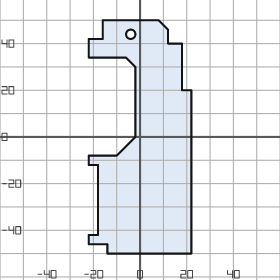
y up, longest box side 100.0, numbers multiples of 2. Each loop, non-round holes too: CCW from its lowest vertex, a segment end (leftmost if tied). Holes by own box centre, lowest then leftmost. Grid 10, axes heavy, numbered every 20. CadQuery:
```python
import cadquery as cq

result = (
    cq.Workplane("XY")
    .moveTo(-14.0, -50.0)
    .lineTo(22.0, -50.0)
    .lineTo(22.0, 20.0)
    .lineTo(18.0, 20.0)
    .lineTo(18.0, 40.0)
    .lineTo(12.0, 40.0)
    .lineTo(12.0, 46.0)
    .lineTo(8.0, 50.0)
    .lineTo(-16.0, 50.0)
    .lineTo(-16.0, 42.0)
    .lineTo(-22.0, 42.0)
    .lineTo(-22.0, 34.0)
    .lineTo(-6.0, 34.0)
    .lineTo(-2.0, 30.0)
    .lineTo(-2.0, 0.0)
    .lineTo(-10.0, -8.0)
    .lineTo(-22.0, -8.0)
    .lineTo(-22.0, -12.0)
    .lineTo(-18.0, -12.0)
    .lineTo(-18.0, -42.0)
    .lineTo(-22.0, -42.0)
    .lineTo(-22.0, -46.0)
    .lineTo(-14.0, -46.0)
    .close()
    .moveTo(-4.0, 44.0)
    .circle(2.0)
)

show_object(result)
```